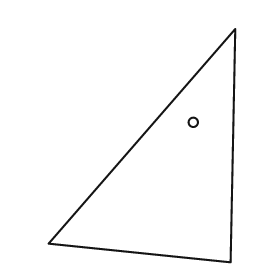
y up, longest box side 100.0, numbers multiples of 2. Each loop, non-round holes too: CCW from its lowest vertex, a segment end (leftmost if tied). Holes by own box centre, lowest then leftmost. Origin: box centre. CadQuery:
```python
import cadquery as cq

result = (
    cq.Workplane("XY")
    .moveTo(38.0, -50.0)
    .lineTo(40.0, 50.0)
    .lineTo(-40.0, -42.0)
    .close()
    .moveTo(22.0, 10.0)
    .circle(2.0)
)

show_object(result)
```